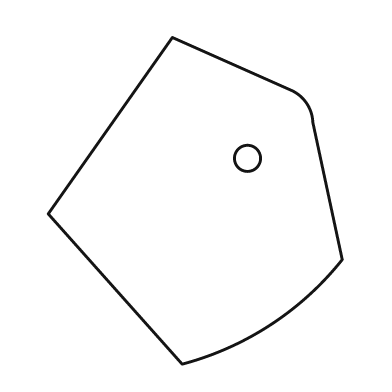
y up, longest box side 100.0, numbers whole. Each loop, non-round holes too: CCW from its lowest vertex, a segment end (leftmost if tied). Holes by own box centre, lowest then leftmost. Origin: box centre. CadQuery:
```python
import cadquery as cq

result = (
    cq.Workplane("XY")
    .moveTo(-4.0, -50.0)
    .threePointArc((23.0, -38.0), (45.0, -18.0))
    .lineTo(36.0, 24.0)
    .threePointArc((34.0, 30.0), (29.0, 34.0))
    .lineTo(-7.0, 50.0)
    .lineTo(-45.0, -4.0)
    .close()
    .moveTo(16.0, 13.0)
    .circle(4.0)
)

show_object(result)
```